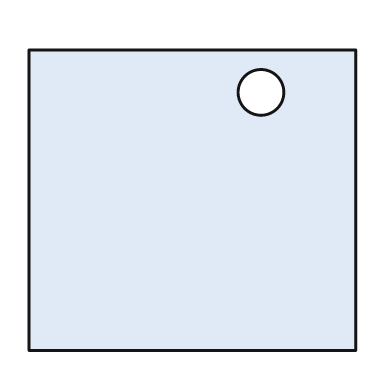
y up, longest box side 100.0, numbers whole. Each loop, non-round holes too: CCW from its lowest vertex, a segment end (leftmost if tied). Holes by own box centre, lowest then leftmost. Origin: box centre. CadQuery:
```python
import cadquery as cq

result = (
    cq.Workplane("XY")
    .moveTo(-50.0, -46.0)
    .lineTo(50.0, -46.0)
    .lineTo(50.0, 46.0)
    .lineTo(-50.0, 46.0)
    .close()
    .moveTo(21.0, 33.0)
    .circle(7.0)
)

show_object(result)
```